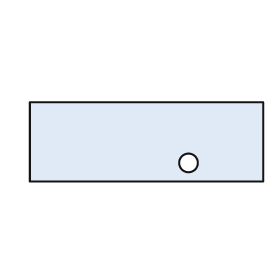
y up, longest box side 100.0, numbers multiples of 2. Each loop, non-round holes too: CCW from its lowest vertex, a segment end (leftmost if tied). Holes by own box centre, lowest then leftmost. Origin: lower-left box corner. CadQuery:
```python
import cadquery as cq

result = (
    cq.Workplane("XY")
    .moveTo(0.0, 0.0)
    .lineTo(100.0, 0.0)
    .lineTo(100.0, 34.0)
    .lineTo(0.0, 34.0)
    .close()
    .moveTo(68.0, 8.0)
    .circle(4.0)
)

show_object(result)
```